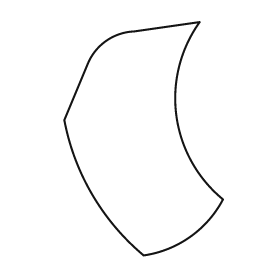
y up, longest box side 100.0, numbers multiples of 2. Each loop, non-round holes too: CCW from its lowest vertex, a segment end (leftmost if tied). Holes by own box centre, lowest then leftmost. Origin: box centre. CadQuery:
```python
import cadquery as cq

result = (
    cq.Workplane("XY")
    .moveTo(0.0, -50.0)
    .threePointArc((20.0, -42.0), (34.0, -26.0))
    .threePointArc((14.0, 10.0), (24.0, 50.0))
    .lineTo(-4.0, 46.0)
    .threePointArc((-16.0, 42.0), (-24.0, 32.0))
    .lineTo(-34.0, 8.0)
    .threePointArc((-22.0, -24.0), (0.0, -50.0))
    .close()
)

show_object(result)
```